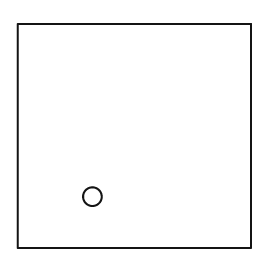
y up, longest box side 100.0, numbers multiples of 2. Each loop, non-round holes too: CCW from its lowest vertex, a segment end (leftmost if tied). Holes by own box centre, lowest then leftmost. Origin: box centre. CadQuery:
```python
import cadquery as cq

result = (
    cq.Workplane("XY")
    .moveTo(-50.0, -48.0)
    .lineTo(50.0, -48.0)
    .lineTo(50.0, 48.0)
    .lineTo(-50.0, 48.0)
    .close()
    .moveTo(-18.0, -26.0)
    .circle(4.0)
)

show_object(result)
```